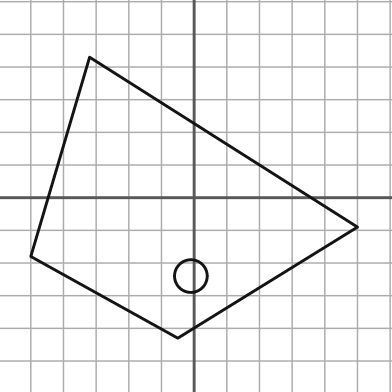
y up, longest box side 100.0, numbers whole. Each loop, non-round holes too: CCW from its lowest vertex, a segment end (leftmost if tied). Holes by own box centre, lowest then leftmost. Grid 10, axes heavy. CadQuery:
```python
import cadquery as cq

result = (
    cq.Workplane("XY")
    .moveTo(-5.0, -43.0)
    .lineTo(50.0, -9.0)
    .lineTo(-32.0, 43.0)
    .lineTo(-50.0, -18.0)
    .close()
    .moveTo(-1.0, -24.0)
    .circle(5.0)
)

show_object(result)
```